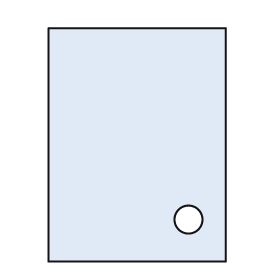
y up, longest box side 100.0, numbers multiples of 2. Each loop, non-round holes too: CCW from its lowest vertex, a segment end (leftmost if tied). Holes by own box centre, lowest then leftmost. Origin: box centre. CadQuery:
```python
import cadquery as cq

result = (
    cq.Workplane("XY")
    .moveTo(-38.0, -50.0)
    .lineTo(38.0, -50.0)
    .lineTo(38.0, 50.0)
    .lineTo(-38.0, 50.0)
    .close()
    .moveTo(22.0, -32.0)
    .circle(6.0)
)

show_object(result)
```